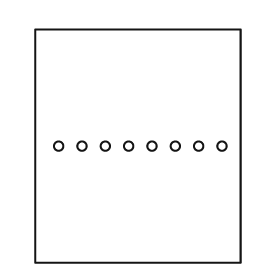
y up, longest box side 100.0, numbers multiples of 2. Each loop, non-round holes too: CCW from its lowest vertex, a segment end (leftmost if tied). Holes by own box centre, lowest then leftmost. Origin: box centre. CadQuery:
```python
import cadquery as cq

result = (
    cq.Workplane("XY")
    .moveTo(-44.0, -50.0)
    .lineTo(44.0, -50.0)
    .lineTo(44.0, 50.0)
    .lineTo(-44.0, 50.0)
    .close()
    .moveTo(-34.0, 0.0)
    .circle(2.0)
    .moveTo(-24.0, 0.0)
    .circle(2.0)
    .moveTo(-14.0, 0.0)
    .circle(2.0)
    .moveTo(-4.0, 0.0)
    .circle(2.0)
    .moveTo(6.0, 0.0)
    .circle(2.0)
    .moveTo(16.0, 0.0)
    .circle(2.0)
    .moveTo(26.0, 0.0)
    .circle(2.0)
    .moveTo(36.0, 0.0)
    .circle(2.0)
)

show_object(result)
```